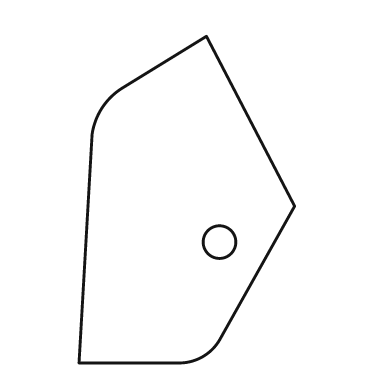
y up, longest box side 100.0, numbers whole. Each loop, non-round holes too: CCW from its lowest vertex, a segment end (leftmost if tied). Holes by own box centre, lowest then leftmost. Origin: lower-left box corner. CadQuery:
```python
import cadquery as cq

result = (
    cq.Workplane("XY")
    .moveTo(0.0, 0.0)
    .lineTo(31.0, 0.0)
    .threePointArc((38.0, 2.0), (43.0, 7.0))
    .lineTo(66.0, 48.0)
    .lineTo(39.0, 100.0)
    .lineTo(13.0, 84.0)
    .threePointArc((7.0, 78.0), (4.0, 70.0))
    .close()
    .moveTo(43.0, 37.0)
    .circle(5.0)
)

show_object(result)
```